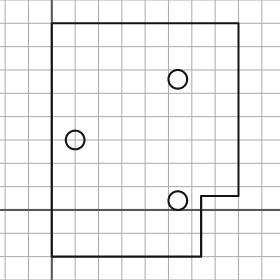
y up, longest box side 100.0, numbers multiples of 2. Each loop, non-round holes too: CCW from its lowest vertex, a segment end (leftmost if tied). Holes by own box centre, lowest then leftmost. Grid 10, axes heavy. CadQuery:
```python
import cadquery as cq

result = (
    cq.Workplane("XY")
    .moveTo(0.0, -20.0)
    .lineTo(64.0, -20.0)
    .lineTo(64.0, 6.0)
    .lineTo(80.0, 6.0)
    .lineTo(80.0, 80.0)
    .lineTo(0.0, 80.0)
    .close()
    .moveTo(54.0, 4.0)
    .circle(4.0)
    .moveTo(10.0, 30.0)
    .circle(4.0)
    .moveTo(54.0, 56.0)
    .circle(4.0)
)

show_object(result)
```